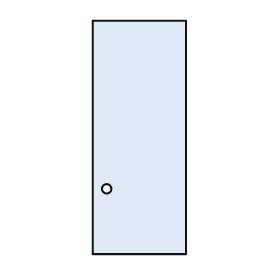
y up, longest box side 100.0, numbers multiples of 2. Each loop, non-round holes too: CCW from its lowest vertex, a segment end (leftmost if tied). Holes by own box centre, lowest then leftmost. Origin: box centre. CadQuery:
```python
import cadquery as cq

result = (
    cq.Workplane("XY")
    .moveTo(-20.0, -50.0)
    .lineTo(20.0, -50.0)
    .lineTo(20.0, 50.0)
    .lineTo(-20.0, 50.0)
    .close()
    .moveTo(-14.0, -22.0)
    .circle(2.0)
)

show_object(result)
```